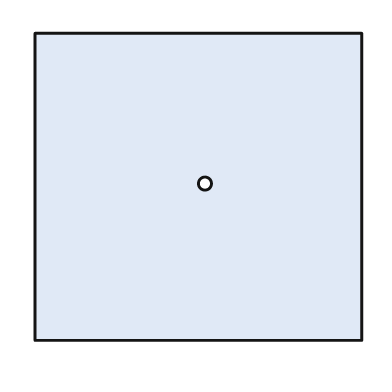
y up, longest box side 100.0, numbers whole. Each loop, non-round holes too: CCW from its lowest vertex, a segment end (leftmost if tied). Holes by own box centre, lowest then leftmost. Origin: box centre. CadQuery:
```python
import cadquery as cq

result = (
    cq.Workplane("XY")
    .moveTo(-50.0, -47.0)
    .lineTo(50.0, -47.0)
    .lineTo(50.0, 47.0)
    .lineTo(-50.0, 47.0)
    .close()
    .moveTo(2.0, 1.0)
    .circle(2.0)
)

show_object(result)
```